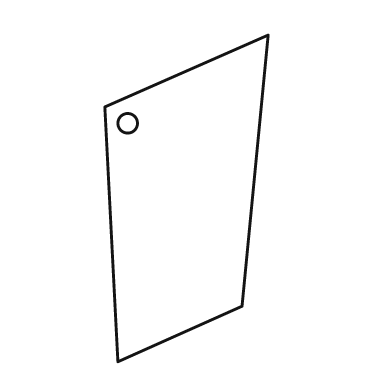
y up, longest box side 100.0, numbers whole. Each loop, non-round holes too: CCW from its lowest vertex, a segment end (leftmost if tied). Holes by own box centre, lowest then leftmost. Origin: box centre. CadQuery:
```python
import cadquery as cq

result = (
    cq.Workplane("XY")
    .moveTo(-21.0, -50.0)
    .lineTo(17.0, -33.0)
    .lineTo(25.0, 50.0)
    .lineTo(-25.0, 28.0)
    .close()
    .moveTo(-18.0, 23.0)
    .circle(3.0)
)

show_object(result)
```